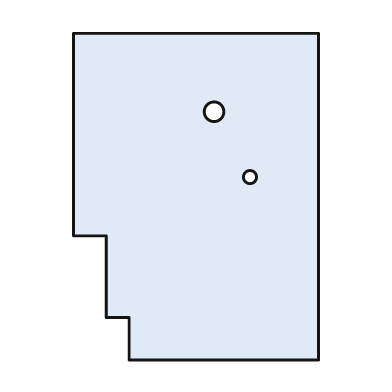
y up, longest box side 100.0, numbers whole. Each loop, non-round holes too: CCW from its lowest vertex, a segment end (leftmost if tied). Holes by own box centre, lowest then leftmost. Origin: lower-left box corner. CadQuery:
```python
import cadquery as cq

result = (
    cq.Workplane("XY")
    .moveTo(17.0, 0.0)
    .lineTo(75.0, 0.0)
    .lineTo(75.0, 100.0)
    .lineTo(0.0, 100.0)
    .lineTo(0.0, 38.0)
    .lineTo(10.0, 38.0)
    .lineTo(10.0, 13.0)
    .lineTo(17.0, 13.0)
    .close()
    .moveTo(54.0, 56.0)
    .circle(2.0)
    .moveTo(43.0, 76.0)
    .circle(3.0)
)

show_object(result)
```